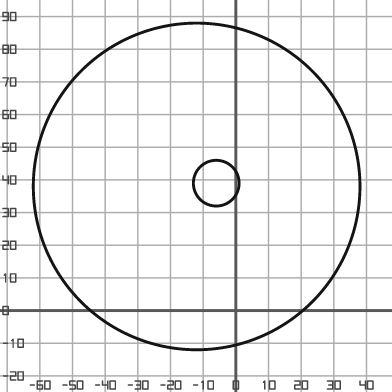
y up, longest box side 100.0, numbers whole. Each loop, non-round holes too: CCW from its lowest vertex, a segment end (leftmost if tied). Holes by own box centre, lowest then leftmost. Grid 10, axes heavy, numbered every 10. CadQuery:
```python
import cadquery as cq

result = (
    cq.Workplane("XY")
    .moveTo(-12.0, 38.0)
    .circle(50.0)
    .moveTo(-6.0, 39.0)
    .circle(7.0)
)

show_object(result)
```